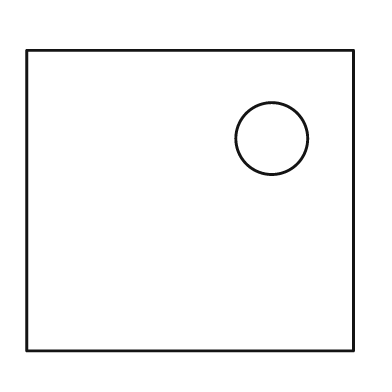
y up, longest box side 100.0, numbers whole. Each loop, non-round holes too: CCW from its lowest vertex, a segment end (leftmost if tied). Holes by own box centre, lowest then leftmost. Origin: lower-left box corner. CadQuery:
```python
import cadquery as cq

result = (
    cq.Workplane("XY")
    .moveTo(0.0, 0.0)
    .lineTo(100.0, 0.0)
    .lineTo(100.0, 92.0)
    .lineTo(0.0, 92.0)
    .close()
    .moveTo(75.0, 65.0)
    .circle(11.0)
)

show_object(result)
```